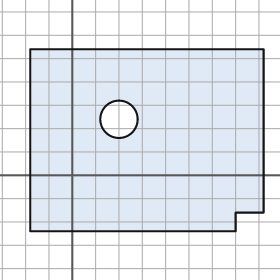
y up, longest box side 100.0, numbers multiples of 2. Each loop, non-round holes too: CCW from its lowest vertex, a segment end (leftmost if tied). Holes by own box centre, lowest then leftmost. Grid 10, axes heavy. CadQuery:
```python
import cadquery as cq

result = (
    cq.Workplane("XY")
    .moveTo(-18.0, -24.0)
    .lineTo(70.0, -24.0)
    .lineTo(70.0, -16.0)
    .lineTo(82.0, -16.0)
    .lineTo(82.0, 54.0)
    .lineTo(-18.0, 54.0)
    .close()
    .moveTo(20.0, 24.0)
    .circle(8.0)
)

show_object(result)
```